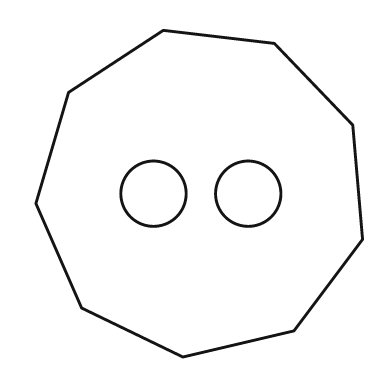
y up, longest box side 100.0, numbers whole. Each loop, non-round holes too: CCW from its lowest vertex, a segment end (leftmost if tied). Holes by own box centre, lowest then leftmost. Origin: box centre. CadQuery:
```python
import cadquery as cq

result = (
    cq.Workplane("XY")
    .moveTo(-5.0, -50.0)
    .lineTo(29.0, -42.0)
    .lineTo(50.0, -14.0)
    .lineTo(47.0, 21.0)
    .lineTo(23.0, 46.0)
    .lineTo(-11.0, 50.0)
    .lineTo(-40.0, 31.0)
    .lineTo(-50.0, -3.0)
    .lineTo(-36.0, -35.0)
    .close()
    .moveTo(-14.0, 0.0)
    .circle(10.0)
    .moveTo(15.0, 0.0)
    .circle(10.0)
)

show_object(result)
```